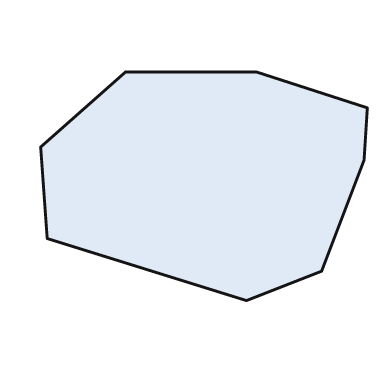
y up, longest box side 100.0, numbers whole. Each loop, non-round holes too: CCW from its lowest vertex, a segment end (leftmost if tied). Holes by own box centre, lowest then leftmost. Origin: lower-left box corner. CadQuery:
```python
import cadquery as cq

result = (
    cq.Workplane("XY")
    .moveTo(63.0, 0.0)
    .lineTo(86.0, 9.0)
    .lineTo(99.0, 43.0)
    .lineTo(100.0, 59.0)
    .lineTo(66.0, 70.0)
    .lineTo(26.0, 70.0)
    .lineTo(0.0, 47.0)
    .lineTo(2.0, 19.0)
    .close()
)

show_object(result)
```